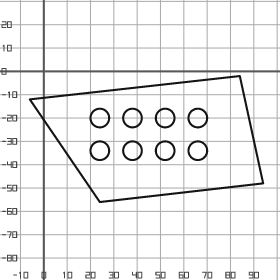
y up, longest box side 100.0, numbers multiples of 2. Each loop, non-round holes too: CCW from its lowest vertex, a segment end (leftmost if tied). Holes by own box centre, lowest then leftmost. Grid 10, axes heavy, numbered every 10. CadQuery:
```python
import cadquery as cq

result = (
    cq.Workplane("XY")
    .moveTo(24.0, -56.0)
    .lineTo(94.0, -48.0)
    .lineTo(84.0, -2.0)
    .lineTo(-6.0, -12.0)
    .close()
    .moveTo(24.0, -34.0)
    .circle(4.0)
    .moveTo(38.0, -34.0)
    .circle(4.0)
    .moveTo(52.0, -34.0)
    .circle(4.0)
    .moveTo(66.0, -34.0)
    .circle(4.0)
    .moveTo(24.0, -20.0)
    .circle(4.0)
    .moveTo(38.0, -20.0)
    .circle(4.0)
    .moveTo(52.0, -20.0)
    .circle(4.0)
    .moveTo(66.0, -20.0)
    .circle(4.0)
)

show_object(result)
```